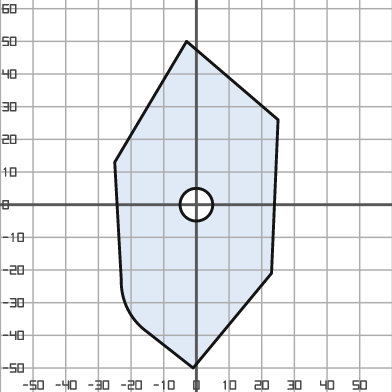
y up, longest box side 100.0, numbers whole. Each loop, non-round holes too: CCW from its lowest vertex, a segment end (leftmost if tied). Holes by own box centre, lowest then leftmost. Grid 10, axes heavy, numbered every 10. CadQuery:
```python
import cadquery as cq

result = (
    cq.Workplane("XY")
    .moveTo(-1.0, -50.0)
    .lineTo(23.0, -21.0)
    .lineTo(25.0, 26.0)
    .lineTo(-3.0, 50.0)
    .lineTo(-25.0, 13.0)
    .lineTo(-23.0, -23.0)
    .threePointArc((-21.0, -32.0), (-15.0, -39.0))
    .close()
    .moveTo(0.0, 0.0)
    .circle(5.0)
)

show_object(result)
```